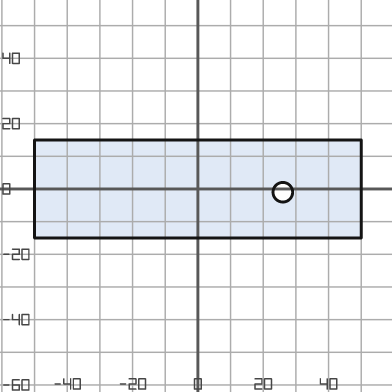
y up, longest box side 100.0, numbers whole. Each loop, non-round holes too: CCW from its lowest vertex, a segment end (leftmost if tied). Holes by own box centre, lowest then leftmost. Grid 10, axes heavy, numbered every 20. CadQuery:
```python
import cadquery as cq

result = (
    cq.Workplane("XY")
    .moveTo(-50.0, -15.0)
    .lineTo(50.0, -15.0)
    .lineTo(50.0, 15.0)
    .lineTo(-50.0, 15.0)
    .close()
    .moveTo(26.0, -1.0)
    .circle(3.0)
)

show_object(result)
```